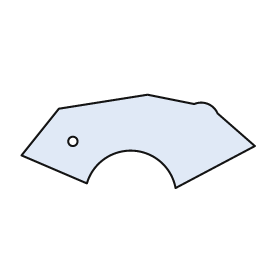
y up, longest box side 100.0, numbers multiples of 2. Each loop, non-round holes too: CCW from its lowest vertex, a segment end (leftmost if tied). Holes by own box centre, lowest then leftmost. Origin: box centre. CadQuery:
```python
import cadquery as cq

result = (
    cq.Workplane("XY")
    .moveTo(16.0, -20.0)
    .lineTo(50.0, -2.0)
    .lineTo(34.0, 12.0)
    .threePointArc((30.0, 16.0), (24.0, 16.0))
    .lineTo(4.0, 20.0)
    .lineTo(-34.0, 14.0)
    .lineTo(-50.0, -6.0)
    .lineTo(-22.0, -18.0)
    .threePointArc((-2.0, -4.0), (16.0, -20.0))
    .close()
    .moveTo(-28.0, 0.0)
    .circle(2.0)
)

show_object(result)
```